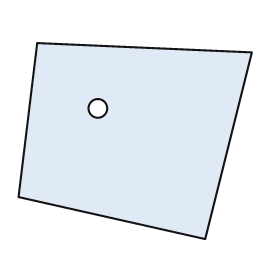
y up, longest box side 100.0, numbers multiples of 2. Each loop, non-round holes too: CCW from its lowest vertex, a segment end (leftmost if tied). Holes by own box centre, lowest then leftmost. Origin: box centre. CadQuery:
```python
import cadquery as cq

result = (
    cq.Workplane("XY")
    .moveTo(30.0, -42.0)
    .lineTo(50.0, 38.0)
    .lineTo(-42.0, 42.0)
    .lineTo(-50.0, -24.0)
    .close()
    .moveTo(-16.0, 14.0)
    .circle(4.0)
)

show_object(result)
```